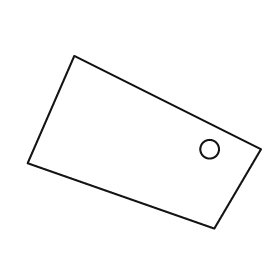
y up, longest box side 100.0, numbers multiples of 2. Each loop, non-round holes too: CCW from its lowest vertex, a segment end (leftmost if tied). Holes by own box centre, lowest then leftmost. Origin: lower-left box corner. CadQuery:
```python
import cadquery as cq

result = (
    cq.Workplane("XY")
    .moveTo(80.0, 0.0)
    .lineTo(100.0, 34.0)
    .lineTo(20.0, 74.0)
    .lineTo(0.0, 28.0)
    .close()
    .moveTo(78.0, 34.0)
    .circle(4.0)
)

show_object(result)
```